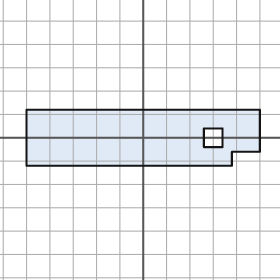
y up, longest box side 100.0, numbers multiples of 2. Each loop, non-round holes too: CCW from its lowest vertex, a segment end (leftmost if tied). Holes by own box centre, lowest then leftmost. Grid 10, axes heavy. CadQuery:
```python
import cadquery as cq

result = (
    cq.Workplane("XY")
    .moveTo(-50.0, -12.0)
    .lineTo(38.0, -12.0)
    .lineTo(38.0, -6.0)
    .lineTo(50.0, -6.0)
    .lineTo(50.0, 12.0)
    .lineTo(-50.0, 12.0)
    .close()
    .moveTo(26.0, -4.0)
    .lineTo(34.0, -4.0)
    .lineTo(34.0, 4.0)
    .lineTo(26.0, 4.0)
    .close()
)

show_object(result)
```